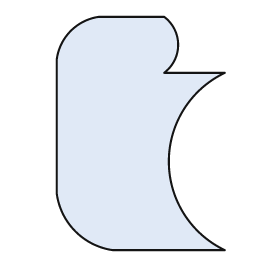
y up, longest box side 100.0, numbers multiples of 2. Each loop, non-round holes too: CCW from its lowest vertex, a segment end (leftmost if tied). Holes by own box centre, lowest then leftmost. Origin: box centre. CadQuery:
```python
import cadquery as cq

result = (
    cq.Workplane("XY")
    .moveTo(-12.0, -50.0)
    .lineTo(36.0, -50.0)
    .threePointArc((12.0, -12.0), (36.0, 26.0))
    .lineTo(10.0, 26.0)
    .threePointArc((16.0, 38.0), (10.0, 50.0))
    .lineTo(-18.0, 50.0)
    .threePointArc((-30.0, 44.0), (-36.0, 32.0))
    .lineTo(-36.0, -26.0)
    .threePointArc((-28.0, -42.0), (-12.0, -50.0))
    .close()
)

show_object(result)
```